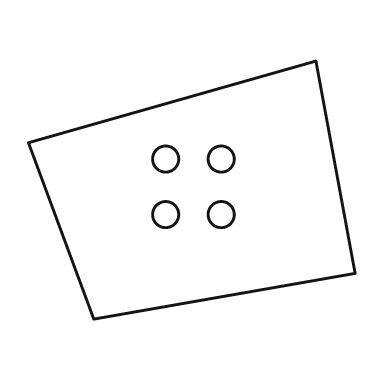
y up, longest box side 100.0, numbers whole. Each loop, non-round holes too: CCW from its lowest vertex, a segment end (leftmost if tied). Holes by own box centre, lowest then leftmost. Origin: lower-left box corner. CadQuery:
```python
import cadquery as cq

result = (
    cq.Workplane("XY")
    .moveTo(20.0, 0.0)
    .lineTo(100.0, 14.0)
    .lineTo(88.0, 79.0)
    .lineTo(0.0, 54.0)
    .close()
    .moveTo(42.0, 32.0)
    .circle(4.0)
    .moveTo(59.0, 32.0)
    .circle(4.0)
    .moveTo(42.0, 49.0)
    .circle(4.0)
    .moveTo(59.0, 49.0)
    .circle(4.0)
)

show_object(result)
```